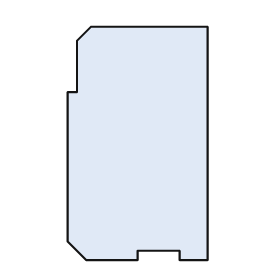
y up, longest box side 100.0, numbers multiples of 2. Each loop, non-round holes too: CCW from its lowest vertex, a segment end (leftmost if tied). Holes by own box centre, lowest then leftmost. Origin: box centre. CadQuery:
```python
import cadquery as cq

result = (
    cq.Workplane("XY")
    .moveTo(-22.0, -50.0)
    .lineTo(0.0, -50.0)
    .lineTo(0.0, -46.0)
    .lineTo(18.0, -46.0)
    .lineTo(18.0, -50.0)
    .lineTo(30.0, -50.0)
    .lineTo(30.0, 50.0)
    .lineTo(-20.0, 50.0)
    .lineTo(-26.0, 44.0)
    .lineTo(-26.0, 22.0)
    .lineTo(-30.0, 22.0)
    .lineTo(-30.0, -42.0)
    .close()
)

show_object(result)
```